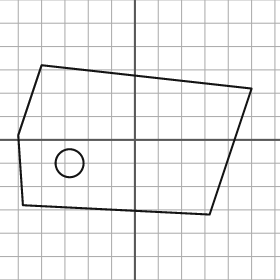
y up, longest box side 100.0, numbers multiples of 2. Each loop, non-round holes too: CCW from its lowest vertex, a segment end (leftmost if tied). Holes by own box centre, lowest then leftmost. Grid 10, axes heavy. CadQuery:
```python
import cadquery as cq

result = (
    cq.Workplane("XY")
    .moveTo(32.0, -32.0)
    .lineTo(50.0, 22.0)
    .lineTo(-40.0, 32.0)
    .lineTo(-50.0, 2.0)
    .lineTo(-48.0, -28.0)
    .close()
    .moveTo(-28.0, -10.0)
    .circle(6.0)
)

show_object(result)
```